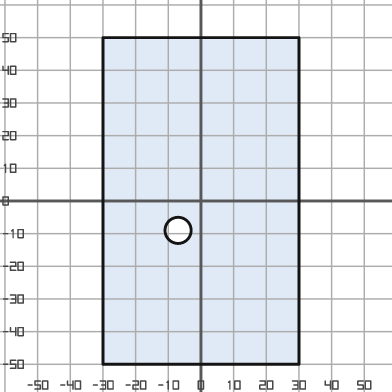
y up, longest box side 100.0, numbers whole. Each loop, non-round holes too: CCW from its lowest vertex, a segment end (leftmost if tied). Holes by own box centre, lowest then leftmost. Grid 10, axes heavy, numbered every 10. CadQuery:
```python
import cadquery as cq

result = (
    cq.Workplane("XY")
    .moveTo(-30.0, -50.0)
    .lineTo(30.0, -50.0)
    .lineTo(30.0, 50.0)
    .lineTo(-30.0, 50.0)
    .close()
    .moveTo(-7.0, -9.0)
    .circle(4.0)
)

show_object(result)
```